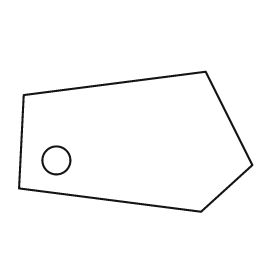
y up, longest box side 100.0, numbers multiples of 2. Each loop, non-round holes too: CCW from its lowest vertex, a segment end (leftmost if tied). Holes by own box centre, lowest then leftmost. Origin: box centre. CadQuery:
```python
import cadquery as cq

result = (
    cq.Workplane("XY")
    .moveTo(28.0, -30.0)
    .lineTo(50.0, -10.0)
    .lineTo(30.0, 30.0)
    .lineTo(-48.0, 20.0)
    .lineTo(-50.0, -20.0)
    .close()
    .moveTo(-34.0, -8.0)
    .circle(6.0)
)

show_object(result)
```